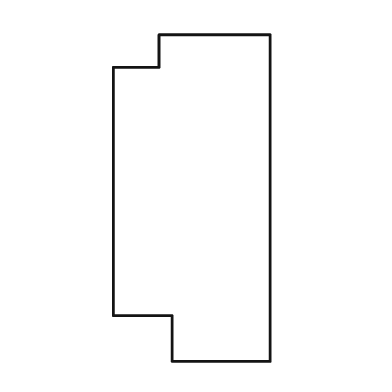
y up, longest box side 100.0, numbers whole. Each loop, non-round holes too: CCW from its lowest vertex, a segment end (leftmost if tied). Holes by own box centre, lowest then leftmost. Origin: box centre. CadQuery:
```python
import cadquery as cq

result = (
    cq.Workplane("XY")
    .moveTo(-6.0, -50.0)
    .lineTo(24.0, -50.0)
    .lineTo(24.0, 50.0)
    .lineTo(-10.0, 50.0)
    .lineTo(-10.0, 40.0)
    .lineTo(-24.0, 40.0)
    .lineTo(-24.0, -36.0)
    .lineTo(-6.0, -36.0)
    .close()
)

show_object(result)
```